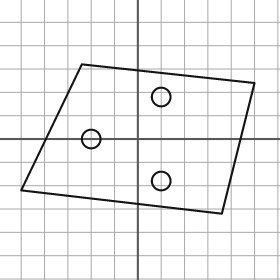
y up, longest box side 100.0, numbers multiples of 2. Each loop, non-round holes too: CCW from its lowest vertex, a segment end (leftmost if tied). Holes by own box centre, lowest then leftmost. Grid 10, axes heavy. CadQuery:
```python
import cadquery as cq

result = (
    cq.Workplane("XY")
    .moveTo(36.0, -32.0)
    .lineTo(50.0, 24.0)
    .lineTo(-24.0, 32.0)
    .lineTo(-50.0, -22.0)
    .close()
    .moveTo(10.0, -18.0)
    .circle(4.0)
    .moveTo(-20.0, 0.0)
    .circle(4.0)
    .moveTo(10.0, 18.0)
    .circle(4.0)
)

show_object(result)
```